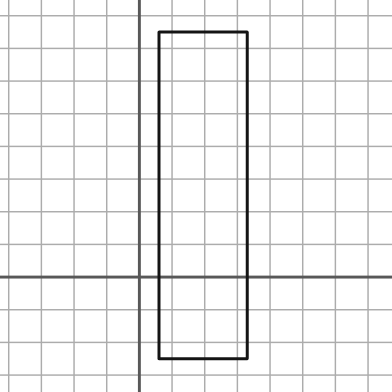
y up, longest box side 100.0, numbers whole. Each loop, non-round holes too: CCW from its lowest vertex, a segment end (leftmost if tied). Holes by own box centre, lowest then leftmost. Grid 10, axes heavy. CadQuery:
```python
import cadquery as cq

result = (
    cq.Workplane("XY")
    .moveTo(6.0, -25.0)
    .lineTo(33.0, -25.0)
    .lineTo(33.0, 75.0)
    .lineTo(6.0, 75.0)
    .close()
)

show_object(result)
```